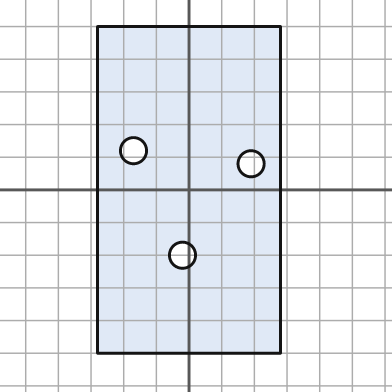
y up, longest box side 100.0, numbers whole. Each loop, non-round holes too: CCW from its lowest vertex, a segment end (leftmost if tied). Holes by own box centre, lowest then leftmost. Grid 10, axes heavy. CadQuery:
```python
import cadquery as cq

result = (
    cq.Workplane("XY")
    .moveTo(-28.0, -50.0)
    .lineTo(28.0, -50.0)
    .lineTo(28.0, 50.0)
    .lineTo(-28.0, 50.0)
    .close()
    .moveTo(-2.0, -20.0)
    .circle(4.0)
    .moveTo(19.0, 8.0)
    .circle(4.0)
    .moveTo(-17.0, 12.0)
    .circle(4.0)
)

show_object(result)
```